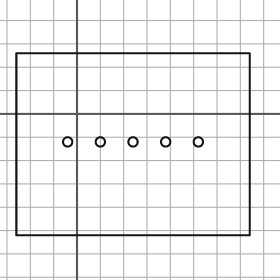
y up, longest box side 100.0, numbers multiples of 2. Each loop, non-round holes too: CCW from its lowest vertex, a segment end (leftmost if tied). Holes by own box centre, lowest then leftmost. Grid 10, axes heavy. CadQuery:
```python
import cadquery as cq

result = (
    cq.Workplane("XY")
    .moveTo(-26.0, -52.0)
    .lineTo(74.0, -52.0)
    .lineTo(74.0, 26.0)
    .lineTo(-26.0, 26.0)
    .close()
    .moveTo(-4.0, -12.0)
    .circle(2.0)
    .moveTo(10.0, -12.0)
    .circle(2.0)
    .moveTo(24.0, -12.0)
    .circle(2.0)
    .moveTo(38.0, -12.0)
    .circle(2.0)
    .moveTo(52.0, -12.0)
    .circle(2.0)
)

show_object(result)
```